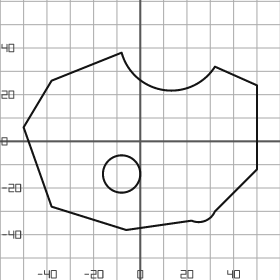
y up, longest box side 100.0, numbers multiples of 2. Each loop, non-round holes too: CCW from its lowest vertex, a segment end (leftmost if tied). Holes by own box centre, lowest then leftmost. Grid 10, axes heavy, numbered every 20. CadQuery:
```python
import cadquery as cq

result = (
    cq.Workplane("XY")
    .moveTo(-6.0, -38.0)
    .lineTo(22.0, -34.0)
    .threePointArc((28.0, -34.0), (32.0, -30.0))
    .lineTo(50.0, -12.0)
    .lineTo(50.0, 24.0)
    .lineTo(32.0, 32.0)
    .threePointArc((10.0, 22.0), (-8.0, 38.0))
    .lineTo(-38.0, 26.0)
    .lineTo(-50.0, 6.0)
    .lineTo(-38.0, -28.0)
    .close()
    .moveTo(-8.0, -14.0)
    .circle(8.0)
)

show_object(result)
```